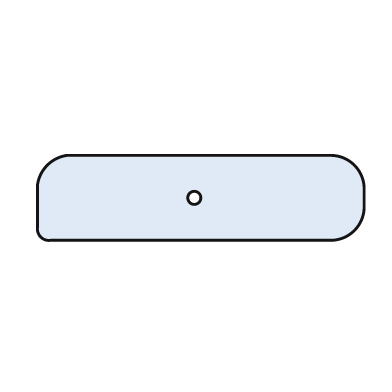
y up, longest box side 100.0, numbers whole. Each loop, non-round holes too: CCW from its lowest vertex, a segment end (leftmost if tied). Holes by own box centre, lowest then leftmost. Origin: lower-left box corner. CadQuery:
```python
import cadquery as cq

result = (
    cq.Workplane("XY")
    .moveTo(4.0, 0.0)
    .lineTo(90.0, 0.0)
    .threePointArc((97.0, 3.0), (100.0, 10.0))
    .lineTo(100.0, 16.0)
    .threePointArc((97.0, 23.0), (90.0, 26.0))
    .lineTo(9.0, 26.0)
    .threePointArc((3.0, 23.0), (0.0, 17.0))
    .lineTo(0.0, 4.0)
    .threePointArc((1.0, 1.0), (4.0, 0.0))
    .close()
    .moveTo(48.0, 13.0)
    .circle(2.0)
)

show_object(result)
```